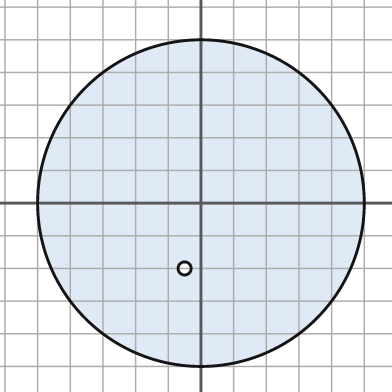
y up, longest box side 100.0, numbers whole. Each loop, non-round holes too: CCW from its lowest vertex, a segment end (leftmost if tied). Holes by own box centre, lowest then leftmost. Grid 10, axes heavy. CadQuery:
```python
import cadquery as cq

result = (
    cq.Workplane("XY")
    .moveTo(0.0, 0.0)
    .circle(50.0)
    .moveTo(-5.0, -20.0)
    .circle(2.0)
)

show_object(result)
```